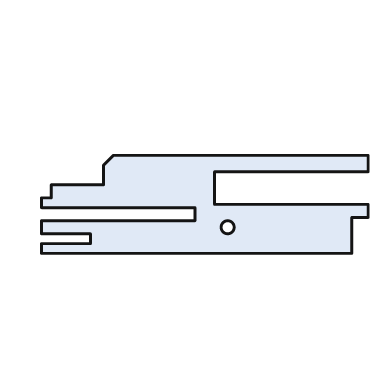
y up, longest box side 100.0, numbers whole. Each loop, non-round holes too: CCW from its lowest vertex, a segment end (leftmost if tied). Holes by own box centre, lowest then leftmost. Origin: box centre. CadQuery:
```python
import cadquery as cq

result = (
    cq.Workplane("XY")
    .moveTo(-50.0, -15.0)
    .lineTo(45.0, -15.0)
    .lineTo(45.0, -4.0)
    .lineTo(50.0, -4.0)
    .lineTo(50.0, 0.0)
    .lineTo(3.0, 0.0)
    .lineTo(3.0, 10.0)
    .lineTo(50.0, 10.0)
    .lineTo(50.0, 15.0)
    .lineTo(-28.0, 15.0)
    .lineTo(-31.0, 12.0)
    .lineTo(-31.0, 6.0)
    .lineTo(-47.0, 6.0)
    .lineTo(-47.0, 2.0)
    .lineTo(-50.0, 2.0)
    .lineTo(-50.0, -1.0)
    .lineTo(-3.0, -1.0)
    .lineTo(-3.0, -5.0)
    .lineTo(-50.0, -5.0)
    .lineTo(-50.0, -9.0)
    .lineTo(-35.0, -9.0)
    .lineTo(-35.0, -12.0)
    .lineTo(-50.0, -12.0)
    .close()
    .moveTo(7.0, -7.0)
    .circle(2.0)
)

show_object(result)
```